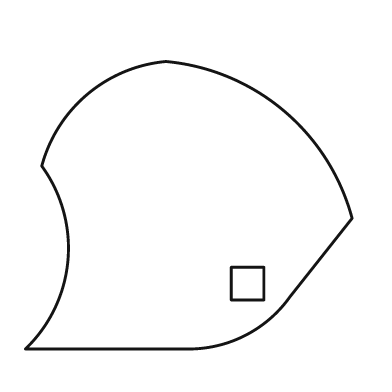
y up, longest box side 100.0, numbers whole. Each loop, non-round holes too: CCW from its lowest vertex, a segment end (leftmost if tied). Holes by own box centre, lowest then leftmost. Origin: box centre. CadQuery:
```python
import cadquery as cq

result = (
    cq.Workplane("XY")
    .moveTo(-50.0, -44.0)
    .lineTo(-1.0, -44.0)
    .threePointArc((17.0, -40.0), (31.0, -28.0))
    .lineTo(50.0, -4.0)
    .threePointArc((29.0, 29.0), (-7.0, 44.0))
    .threePointArc((-31.0, 34.0), (-45.0, 12.0))
    .threePointArc((-37.0, -17.0), (-50.0, -44.0))
    .close()
    .moveTo(13.0, -29.0)
    .lineTo(23.0, -29.0)
    .lineTo(23.0, -19.0)
    .lineTo(13.0, -19.0)
    .close()
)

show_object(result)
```